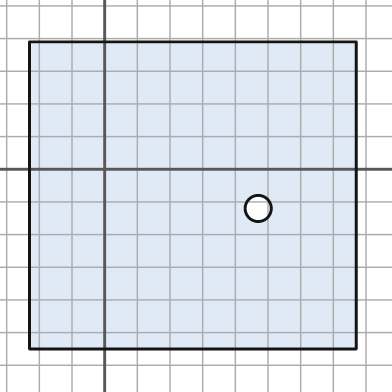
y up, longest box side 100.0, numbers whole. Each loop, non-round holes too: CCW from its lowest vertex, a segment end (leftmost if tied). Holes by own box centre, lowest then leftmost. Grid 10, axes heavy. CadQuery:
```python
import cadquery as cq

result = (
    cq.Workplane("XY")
    .moveTo(-23.0, -55.0)
    .lineTo(77.0, -55.0)
    .lineTo(77.0, 39.0)
    .lineTo(-23.0, 39.0)
    .close()
    .moveTo(47.0, -12.0)
    .circle(4.0)
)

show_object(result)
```